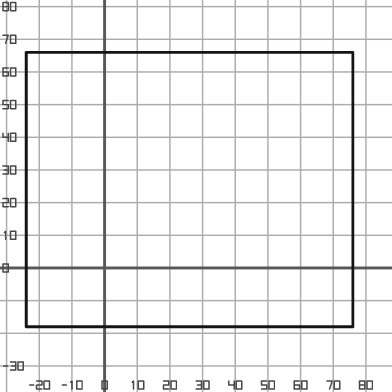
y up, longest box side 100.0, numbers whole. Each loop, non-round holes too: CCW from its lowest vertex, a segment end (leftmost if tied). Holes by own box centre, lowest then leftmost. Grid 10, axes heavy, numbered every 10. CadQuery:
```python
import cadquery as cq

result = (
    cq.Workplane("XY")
    .moveTo(-24.0, -18.0)
    .lineTo(76.0, -18.0)
    .lineTo(76.0, 66.0)
    .lineTo(-24.0, 66.0)
    .close()
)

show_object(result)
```